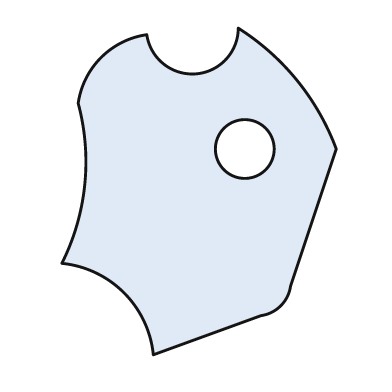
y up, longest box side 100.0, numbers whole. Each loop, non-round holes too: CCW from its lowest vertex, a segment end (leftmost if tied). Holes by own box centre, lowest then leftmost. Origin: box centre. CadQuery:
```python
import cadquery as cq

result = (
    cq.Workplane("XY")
    .moveTo(-14.0, -50.0)
    .lineTo(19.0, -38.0)
    .threePointArc((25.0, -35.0), (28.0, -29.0))
    .lineTo(42.0, 13.0)
    .threePointArc((30.0, 34.0), (12.0, 50.0))
    .threePointArc((-1.0, 36.0), (-16.0, 48.0))
    .threePointArc((-30.0, 41.0), (-37.0, 27.0))
    .threePointArc((-35.0, 2.0), (-42.0, -22.0))
    .threePointArc((-23.0, -31.0), (-14.0, -50.0))
    .close()
    .moveTo(14.0, 13.0)
    .circle(9.0)
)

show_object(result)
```